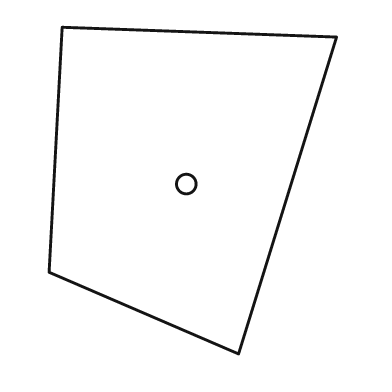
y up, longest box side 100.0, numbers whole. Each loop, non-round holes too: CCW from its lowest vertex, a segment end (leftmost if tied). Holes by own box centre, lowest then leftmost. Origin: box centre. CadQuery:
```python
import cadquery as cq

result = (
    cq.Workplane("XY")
    .moveTo(14.0, -50.0)
    .lineTo(44.0, 47.0)
    .lineTo(-40.0, 50.0)
    .lineTo(-44.0, -25.0)
    .close()
    .moveTo(-2.0, 2.0)
    .circle(3.0)
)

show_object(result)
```